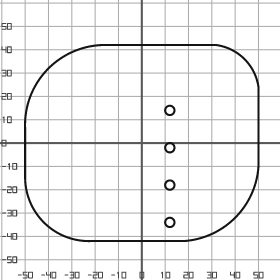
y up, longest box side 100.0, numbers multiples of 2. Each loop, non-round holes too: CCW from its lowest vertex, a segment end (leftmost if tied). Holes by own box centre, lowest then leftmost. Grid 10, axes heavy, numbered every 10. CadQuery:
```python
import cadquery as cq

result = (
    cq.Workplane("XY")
    .moveTo(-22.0, -42.0)
    .lineTo(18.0, -42.0)
    .threePointArc((40.0, -32.0), (50.0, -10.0))
    .lineTo(50.0, 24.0)
    .threePointArc((44.0, 36.0), (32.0, 42.0))
    .lineTo(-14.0, 42.0)
    .threePointArc((-40.0, 32.0), (-50.0, 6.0))
    .lineTo(-50.0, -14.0)
    .threePointArc((-42.0, -34.0), (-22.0, -42.0))
    .close()
    .moveTo(12.0, -34.0)
    .circle(2.0)
    .moveTo(12.0, -18.0)
    .circle(2.0)
    .moveTo(12.0, -2.0)
    .circle(2.0)
    .moveTo(12.0, 14.0)
    .circle(2.0)
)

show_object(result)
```